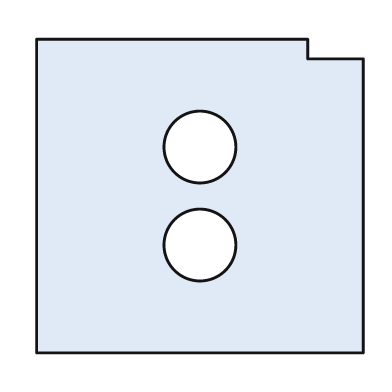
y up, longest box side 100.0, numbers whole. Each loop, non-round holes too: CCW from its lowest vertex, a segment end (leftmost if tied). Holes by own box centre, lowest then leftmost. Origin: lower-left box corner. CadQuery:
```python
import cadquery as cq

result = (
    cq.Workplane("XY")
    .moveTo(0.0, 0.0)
    .lineTo(100.0, 0.0)
    .lineTo(100.0, 90.0)
    .lineTo(83.0, 90.0)
    .lineTo(83.0, 96.0)
    .lineTo(0.0, 96.0)
    .close()
    .moveTo(50.0, 33.0)
    .circle(11.0)
    .moveTo(50.0, 63.0)
    .circle(11.0)
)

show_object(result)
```